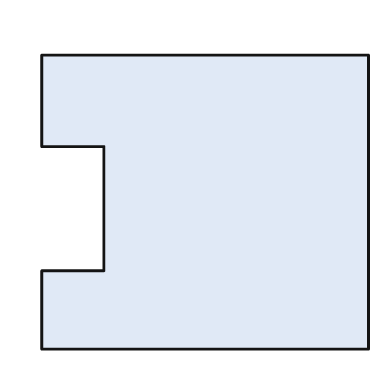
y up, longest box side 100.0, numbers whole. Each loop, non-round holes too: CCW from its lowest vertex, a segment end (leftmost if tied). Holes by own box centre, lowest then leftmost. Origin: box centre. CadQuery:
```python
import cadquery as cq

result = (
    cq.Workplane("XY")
    .moveTo(-50.0, -45.0)
    .lineTo(50.0, -45.0)
    .lineTo(50.0, 45.0)
    .lineTo(-50.0, 45.0)
    .lineTo(-50.0, 17.0)
    .lineTo(-31.0, 17.0)
    .lineTo(-31.0, -21.0)
    .lineTo(-50.0, -21.0)
    .close()
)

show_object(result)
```